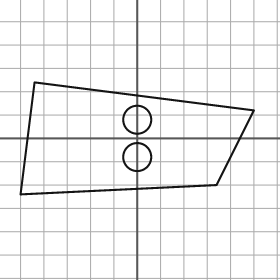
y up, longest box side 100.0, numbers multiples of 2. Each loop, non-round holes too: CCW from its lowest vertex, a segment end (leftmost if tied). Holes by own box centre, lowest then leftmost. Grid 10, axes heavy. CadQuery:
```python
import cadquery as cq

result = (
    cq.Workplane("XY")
    .moveTo(-50.0, -24.0)
    .lineTo(34.0, -20.0)
    .lineTo(50.0, 12.0)
    .lineTo(-44.0, 24.0)
    .close()
    .moveTo(0.0, -8.0)
    .circle(6.0)
    .moveTo(0.0, 8.0)
    .circle(6.0)
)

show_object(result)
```